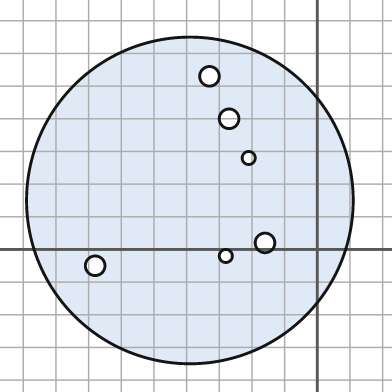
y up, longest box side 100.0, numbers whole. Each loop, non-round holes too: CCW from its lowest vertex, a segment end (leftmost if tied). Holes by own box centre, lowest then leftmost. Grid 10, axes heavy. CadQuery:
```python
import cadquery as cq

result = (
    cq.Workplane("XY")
    .moveTo(-39.0, 15.0)
    .circle(50.0)
    .moveTo(-68.0, -5.0)
    .circle(3.0)
    .moveTo(-28.0, -2.0)
    .circle(2.0)
    .moveTo(-16.0, 2.0)
    .circle(3.0)
    .moveTo(-21.0, 28.0)
    .circle(2.0)
    .moveTo(-27.0, 40.0)
    .circle(3.0)
    .moveTo(-33.0, 53.0)
    .circle(3.0)
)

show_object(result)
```